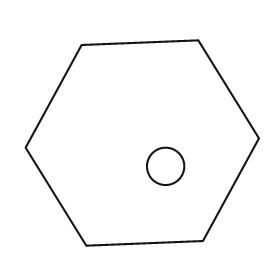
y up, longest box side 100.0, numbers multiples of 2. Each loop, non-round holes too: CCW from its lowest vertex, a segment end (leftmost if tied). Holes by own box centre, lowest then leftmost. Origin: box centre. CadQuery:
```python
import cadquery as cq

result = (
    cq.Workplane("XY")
    .moveTo(-24.0, -44.0)
    .lineTo(26.0, -42.0)
    .lineTo(50.0, 2.0)
    .lineTo(24.0, 44.0)
    .lineTo(-26.0, 42.0)
    .lineTo(-50.0, -2.0)
    .close()
    .moveTo(10.0, -10.0)
    .circle(8.0)
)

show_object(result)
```